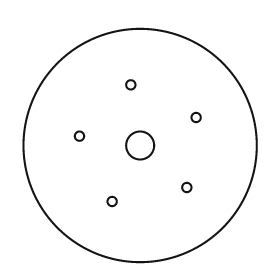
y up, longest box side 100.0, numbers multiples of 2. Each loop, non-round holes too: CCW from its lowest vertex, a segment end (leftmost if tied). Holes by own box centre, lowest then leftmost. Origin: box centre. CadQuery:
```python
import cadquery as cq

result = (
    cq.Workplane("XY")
    .moveTo(0.0, 0.0)
    .circle(50.0)
    .moveTo(-12.0, -24.0)
    .circle(2.0)
    .moveTo(20.0, -18.0)
    .circle(2.0)
    .moveTo(0.0, 0.0)
    .circle(6.0)
    .moveTo(-26.0, 4.0)
    .circle(2.0)
    .moveTo(24.0, 12.0)
    .circle(2.0)
    .moveTo(-4.0, 26.0)
    .circle(2.0)
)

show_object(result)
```